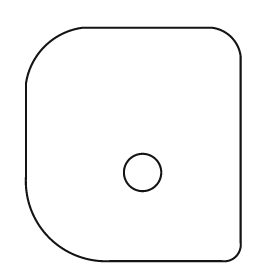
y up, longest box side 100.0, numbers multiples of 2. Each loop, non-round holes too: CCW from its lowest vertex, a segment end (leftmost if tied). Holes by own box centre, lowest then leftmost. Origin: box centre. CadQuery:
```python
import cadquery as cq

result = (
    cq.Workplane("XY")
    .moveTo(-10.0, -50.0)
    .lineTo(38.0, -50.0)
    .threePointArc((44.0, -48.0), (46.0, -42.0))
    .lineTo(46.0, 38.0)
    .threePointArc((42.0, 46.0), (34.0, 50.0))
    .lineTo(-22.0, 50.0)
    .threePointArc((-38.0, 42.0), (-46.0, 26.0))
    .lineTo(-46.0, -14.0)
    .threePointArc((-36.0, -40.0), (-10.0, -50.0))
    .close()
    .moveTo(4.0, -12.0)
    .circle(8.0)
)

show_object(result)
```